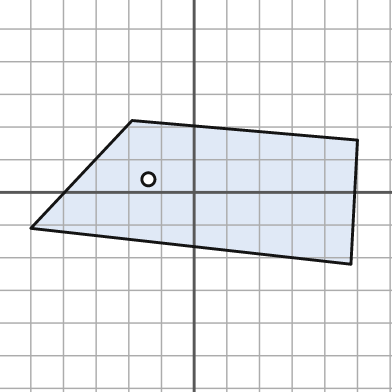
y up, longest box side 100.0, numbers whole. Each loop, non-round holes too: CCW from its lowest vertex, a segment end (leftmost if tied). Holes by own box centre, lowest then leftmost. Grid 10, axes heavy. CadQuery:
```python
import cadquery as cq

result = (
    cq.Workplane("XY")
    .moveTo(48.0, -22.0)
    .lineTo(50.0, 16.0)
    .lineTo(-19.0, 22.0)
    .lineTo(-50.0, -11.0)
    .close()
    .moveTo(-14.0, 4.0)
    .circle(2.0)
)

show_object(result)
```